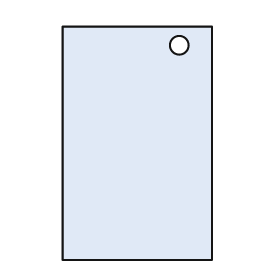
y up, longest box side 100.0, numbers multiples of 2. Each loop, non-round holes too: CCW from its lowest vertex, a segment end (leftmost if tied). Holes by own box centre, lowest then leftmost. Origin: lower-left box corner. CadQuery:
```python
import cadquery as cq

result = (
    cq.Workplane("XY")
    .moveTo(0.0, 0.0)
    .lineTo(64.0, 0.0)
    .lineTo(64.0, 100.0)
    .lineTo(0.0, 100.0)
    .close()
    .moveTo(50.0, 92.0)
    .circle(4.0)
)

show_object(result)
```